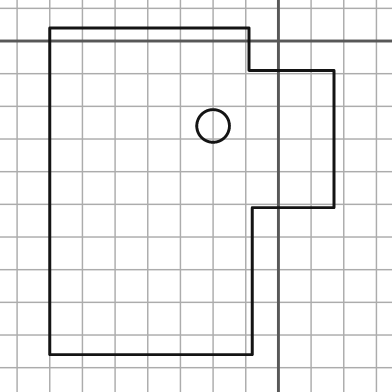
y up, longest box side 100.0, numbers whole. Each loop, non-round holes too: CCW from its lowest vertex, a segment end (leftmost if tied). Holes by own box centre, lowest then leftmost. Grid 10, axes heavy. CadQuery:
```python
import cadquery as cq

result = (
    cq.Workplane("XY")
    .moveTo(-70.0, -96.0)
    .lineTo(-8.0, -96.0)
    .lineTo(-8.0, -51.0)
    .lineTo(17.0, -51.0)
    .lineTo(17.0, -9.0)
    .lineTo(-9.0, -9.0)
    .lineTo(-9.0, 4.0)
    .lineTo(-70.0, 4.0)
    .close()
    .moveTo(-20.0, -26.0)
    .circle(5.0)
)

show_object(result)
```